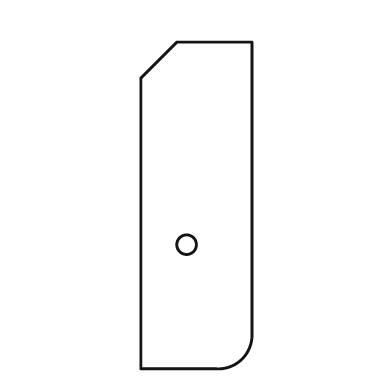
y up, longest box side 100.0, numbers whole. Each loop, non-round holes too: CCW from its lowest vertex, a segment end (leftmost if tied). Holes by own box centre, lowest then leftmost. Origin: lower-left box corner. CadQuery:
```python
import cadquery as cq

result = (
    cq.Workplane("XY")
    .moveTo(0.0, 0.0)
    .lineTo(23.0, 0.0)
    .threePointArc((31.0, 3.0), (34.0, 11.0))
    .lineTo(34.0, 100.0)
    .lineTo(11.0, 100.0)
    .lineTo(0.0, 89.0)
    .close()
    .moveTo(14.0, 38.0)
    .circle(3.0)
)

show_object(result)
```